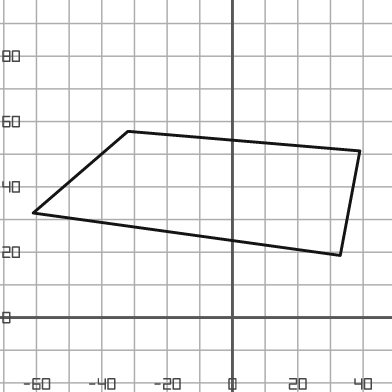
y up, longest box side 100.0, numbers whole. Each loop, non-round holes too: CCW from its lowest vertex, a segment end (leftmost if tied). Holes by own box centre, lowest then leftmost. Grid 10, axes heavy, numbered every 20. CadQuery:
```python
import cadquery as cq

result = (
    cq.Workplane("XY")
    .moveTo(33.0, 19.0)
    .lineTo(39.0, 51.0)
    .lineTo(-32.0, 57.0)
    .lineTo(-61.0, 32.0)
    .close()
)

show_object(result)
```